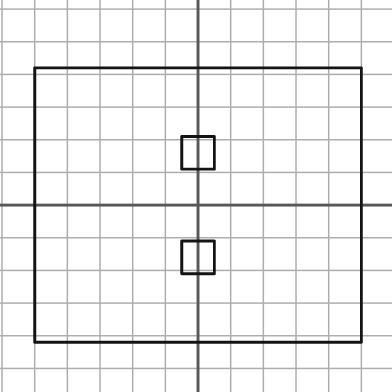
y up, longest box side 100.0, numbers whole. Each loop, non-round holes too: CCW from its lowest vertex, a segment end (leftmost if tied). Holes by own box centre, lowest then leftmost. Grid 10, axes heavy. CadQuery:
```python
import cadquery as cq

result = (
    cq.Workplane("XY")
    .moveTo(-50.0, -42.0)
    .lineTo(50.0, -42.0)
    .lineTo(50.0, 42.0)
    .lineTo(-50.0, 42.0)
    .close()
    .moveTo(-5.0, -21.0)
    .lineTo(5.0, -21.0)
    .lineTo(5.0, -11.0)
    .lineTo(-5.0, -11.0)
    .close()
    .moveTo(-5.0, 11.0)
    .lineTo(5.0, 11.0)
    .lineTo(5.0, 21.0)
    .lineTo(-5.0, 21.0)
    .close()
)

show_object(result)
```